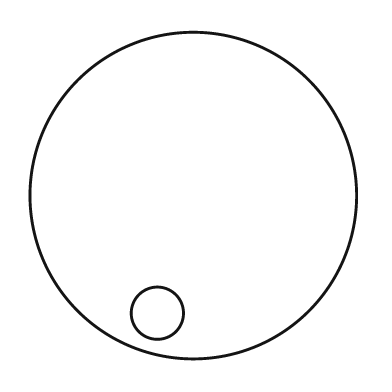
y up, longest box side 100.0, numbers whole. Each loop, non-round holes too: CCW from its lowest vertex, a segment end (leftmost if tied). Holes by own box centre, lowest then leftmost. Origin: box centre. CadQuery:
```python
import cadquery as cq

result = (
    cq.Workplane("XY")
    .moveTo(0.0, 0.0)
    .circle(50.0)
    .moveTo(-11.0, -36.0)
    .circle(8.0)
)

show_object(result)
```